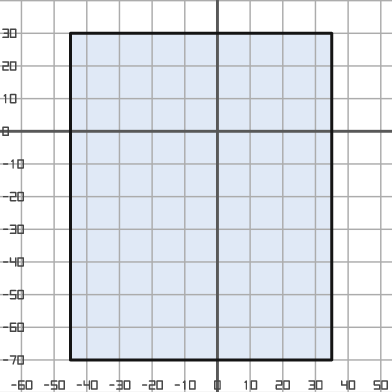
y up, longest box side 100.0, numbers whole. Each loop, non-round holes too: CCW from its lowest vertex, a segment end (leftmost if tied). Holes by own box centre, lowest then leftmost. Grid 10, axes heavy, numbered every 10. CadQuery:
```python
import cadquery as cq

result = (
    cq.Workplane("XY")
    .moveTo(-45.0, -70.0)
    .lineTo(35.0, -70.0)
    .lineTo(35.0, 30.0)
    .lineTo(-45.0, 30.0)
    .close()
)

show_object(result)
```